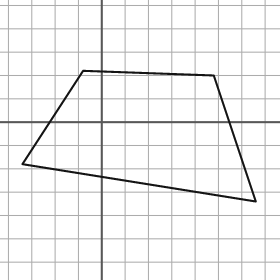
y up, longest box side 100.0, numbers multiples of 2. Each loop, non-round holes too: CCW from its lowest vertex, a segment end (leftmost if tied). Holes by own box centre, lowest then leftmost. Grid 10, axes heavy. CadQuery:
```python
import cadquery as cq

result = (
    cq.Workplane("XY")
    .moveTo(66.0, -34.0)
    .lineTo(48.0, 20.0)
    .lineTo(-8.0, 22.0)
    .lineTo(-34.0, -18.0)
    .close()
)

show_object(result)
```